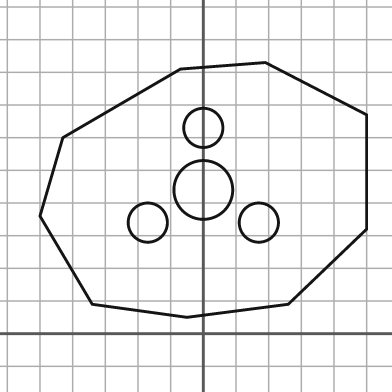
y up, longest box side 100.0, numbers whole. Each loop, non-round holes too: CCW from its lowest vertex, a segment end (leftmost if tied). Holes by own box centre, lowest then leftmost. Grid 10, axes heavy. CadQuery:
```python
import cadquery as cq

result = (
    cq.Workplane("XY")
    .moveTo(-5.0, 5.0)
    .lineTo(26.0, 9.0)
    .lineTo(50.0, 32.0)
    .lineTo(50.0, 67.0)
    .lineTo(19.0, 83.0)
    .lineTo(-7.0, 81.0)
    .lineTo(-43.0, 60.0)
    .lineTo(-50.0, 36.0)
    .lineTo(-34.0, 9.0)
    .close()
    .moveTo(-17.0, 34.0)
    .circle(6.0)
    .moveTo(17.0, 34.0)
    .circle(6.0)
    .moveTo(0.0, 44.0)
    .circle(9.0)
    .moveTo(0.0, 63.0)
    .circle(6.0)
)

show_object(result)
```